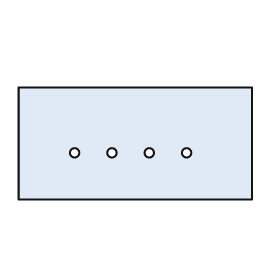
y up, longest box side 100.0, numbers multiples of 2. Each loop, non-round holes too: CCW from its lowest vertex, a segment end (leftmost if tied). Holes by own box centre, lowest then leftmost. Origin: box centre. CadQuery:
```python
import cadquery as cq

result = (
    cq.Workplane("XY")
    .moveTo(-50.0, -24.0)
    .lineTo(50.0, -24.0)
    .lineTo(50.0, 24.0)
    .lineTo(-50.0, 24.0)
    .close()
    .moveTo(-26.0, -4.0)
    .circle(2.0)
    .moveTo(-10.0, -4.0)
    .circle(2.0)
    .moveTo(6.0, -4.0)
    .circle(2.0)
    .moveTo(22.0, -4.0)
    .circle(2.0)
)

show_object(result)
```